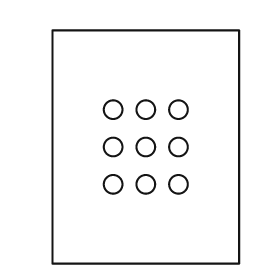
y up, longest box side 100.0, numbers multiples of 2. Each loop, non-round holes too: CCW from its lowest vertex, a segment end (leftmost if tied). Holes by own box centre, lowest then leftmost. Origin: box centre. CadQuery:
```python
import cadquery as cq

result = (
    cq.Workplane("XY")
    .moveTo(-40.0, -50.0)
    .lineTo(40.0, -50.0)
    .lineTo(40.0, 50.0)
    .lineTo(-40.0, 50.0)
    .close()
    .moveTo(-14.0, -16.0)
    .circle(4.0)
    .moveTo(0.0, -16.0)
    .circle(4.0)
    .moveTo(14.0, -16.0)
    .circle(4.0)
    .moveTo(-14.0, 0.0)
    .circle(4.0)
    .moveTo(0.0, 0.0)
    .circle(4.0)
    .moveTo(14.0, 0.0)
    .circle(4.0)
    .moveTo(-14.0, 16.0)
    .circle(4.0)
    .moveTo(0.0, 16.0)
    .circle(4.0)
    .moveTo(14.0, 16.0)
    .circle(4.0)
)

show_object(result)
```